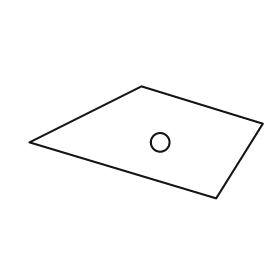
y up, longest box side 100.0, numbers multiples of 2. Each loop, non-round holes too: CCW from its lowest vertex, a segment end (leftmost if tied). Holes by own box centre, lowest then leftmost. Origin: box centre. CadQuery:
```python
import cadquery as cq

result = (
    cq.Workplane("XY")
    .moveTo(30.0, -24.0)
    .lineTo(50.0, 8.0)
    .lineTo(-2.0, 24.0)
    .lineTo(-50.0, 0.0)
    .close()
    .moveTo(6.0, 0.0)
    .circle(4.0)
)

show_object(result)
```